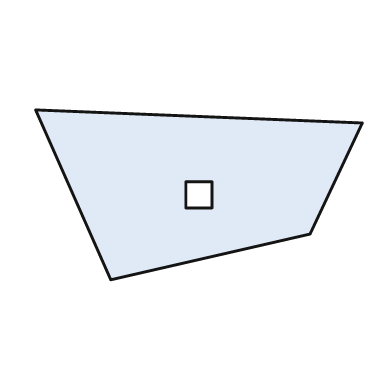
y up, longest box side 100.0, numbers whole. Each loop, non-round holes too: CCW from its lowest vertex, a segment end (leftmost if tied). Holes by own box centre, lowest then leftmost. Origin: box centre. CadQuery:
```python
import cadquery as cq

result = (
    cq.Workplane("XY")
    .moveTo(-27.0, -26.0)
    .lineTo(34.0, -12.0)
    .lineTo(50.0, 22.0)
    .lineTo(-50.0, 26.0)
    .close()
    .moveTo(-4.0, -4.0)
    .lineTo(4.0, -4.0)
    .lineTo(4.0, 4.0)
    .lineTo(-4.0, 4.0)
    .close()
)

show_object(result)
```